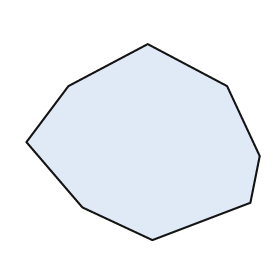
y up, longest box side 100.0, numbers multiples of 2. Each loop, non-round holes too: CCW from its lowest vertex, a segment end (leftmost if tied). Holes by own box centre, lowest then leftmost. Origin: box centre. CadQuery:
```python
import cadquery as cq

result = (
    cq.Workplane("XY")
    .moveTo(4.0, -42.0)
    .lineTo(46.0, -26.0)
    .lineTo(50.0, -6.0)
    .lineTo(36.0, 24.0)
    .lineTo(2.0, 42.0)
    .lineTo(-32.0, 24.0)
    .lineTo(-50.0, 0.0)
    .lineTo(-26.0, -28.0)
    .close()
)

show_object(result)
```